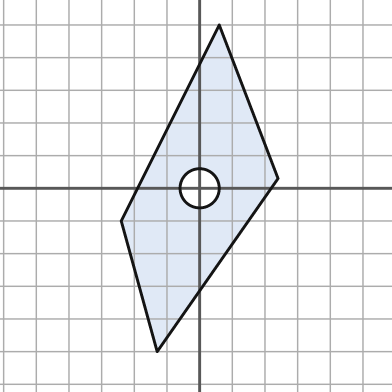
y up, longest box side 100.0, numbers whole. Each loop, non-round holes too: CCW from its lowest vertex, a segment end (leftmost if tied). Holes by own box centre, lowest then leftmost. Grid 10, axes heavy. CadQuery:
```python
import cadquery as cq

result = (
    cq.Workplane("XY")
    .moveTo(-13.0, -50.0)
    .lineTo(24.0, 3.0)
    .lineTo(6.0, 50.0)
    .lineTo(-24.0, -10.0)
    .close()
    .moveTo(0.0, 0.0)
    .circle(6.0)
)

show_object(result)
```